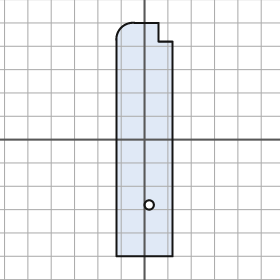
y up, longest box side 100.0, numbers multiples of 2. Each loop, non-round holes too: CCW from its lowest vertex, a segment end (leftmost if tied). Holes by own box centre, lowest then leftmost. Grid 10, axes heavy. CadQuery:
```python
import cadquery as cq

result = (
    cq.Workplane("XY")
    .moveTo(-12.0, -50.0)
    .lineTo(12.0, -50.0)
    .lineTo(12.0, 42.0)
    .lineTo(6.0, 42.0)
    .lineTo(6.0, 50.0)
    .lineTo(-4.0, 50.0)
    .threePointArc((-10.0, 48.0), (-12.0, 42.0))
    .close()
    .moveTo(2.0, -28.0)
    .circle(2.0)
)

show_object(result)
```